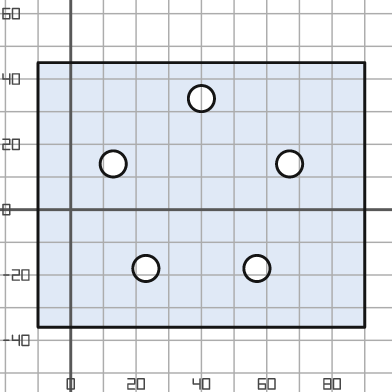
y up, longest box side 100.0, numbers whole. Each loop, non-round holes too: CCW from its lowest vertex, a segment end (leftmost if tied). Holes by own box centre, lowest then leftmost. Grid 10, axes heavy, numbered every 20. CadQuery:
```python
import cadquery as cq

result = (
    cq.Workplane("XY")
    .moveTo(-10.0, -36.0)
    .lineTo(90.0, -36.0)
    .lineTo(90.0, 45.0)
    .lineTo(-10.0, 45.0)
    .close()
    .moveTo(23.0, -18.0)
    .circle(4.0)
    .moveTo(57.0, -18.0)
    .circle(4.0)
    .moveTo(13.0, 14.0)
    .circle(4.0)
    .moveTo(67.0, 14.0)
    .circle(4.0)
    .moveTo(40.0, 34.0)
    .circle(4.0)
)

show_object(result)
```